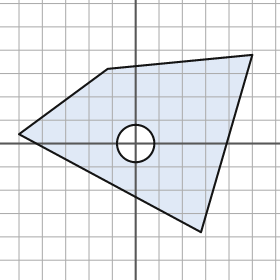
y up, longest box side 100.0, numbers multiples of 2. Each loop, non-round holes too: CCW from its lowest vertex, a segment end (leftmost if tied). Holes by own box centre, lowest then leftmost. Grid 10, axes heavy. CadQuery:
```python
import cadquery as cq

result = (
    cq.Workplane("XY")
    .moveTo(28.0, -38.0)
    .lineTo(50.0, 38.0)
    .lineTo(-12.0, 32.0)
    .lineTo(-50.0, 4.0)
    .close()
    .moveTo(0.0, 0.0)
    .circle(8.0)
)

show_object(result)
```